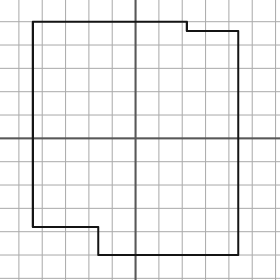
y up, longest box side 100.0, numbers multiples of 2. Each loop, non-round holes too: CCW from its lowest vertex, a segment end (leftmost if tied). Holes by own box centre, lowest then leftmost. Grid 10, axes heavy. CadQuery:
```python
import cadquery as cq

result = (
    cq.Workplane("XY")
    .moveTo(-16.0, -50.0)
    .lineTo(44.0, -50.0)
    .lineTo(44.0, 46.0)
    .lineTo(22.0, 46.0)
    .lineTo(22.0, 50.0)
    .lineTo(-44.0, 50.0)
    .lineTo(-44.0, -38.0)
    .lineTo(-16.0, -38.0)
    .close()
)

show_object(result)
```